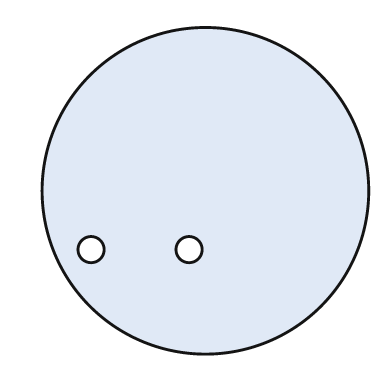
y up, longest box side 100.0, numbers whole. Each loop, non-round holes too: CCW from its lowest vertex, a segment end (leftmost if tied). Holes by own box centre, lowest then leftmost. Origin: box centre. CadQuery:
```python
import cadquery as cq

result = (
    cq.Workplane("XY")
    .moveTo(0.0, 0.0)
    .circle(50.0)
    .moveTo(-35.0, -18.0)
    .circle(4.0)
    .moveTo(-5.0, -18.0)
    .circle(4.0)
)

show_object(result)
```